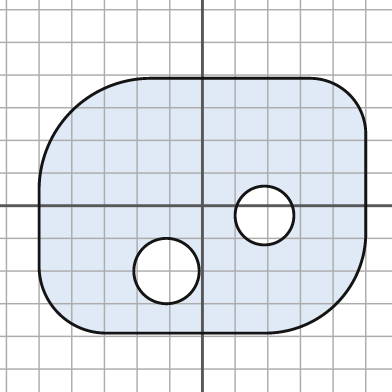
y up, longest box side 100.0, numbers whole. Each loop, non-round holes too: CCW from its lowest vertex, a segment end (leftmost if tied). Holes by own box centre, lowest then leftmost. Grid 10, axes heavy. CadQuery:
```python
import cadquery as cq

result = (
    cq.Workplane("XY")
    .moveTo(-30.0, -39.0)
    .lineTo(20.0, -39.0)
    .threePointArc((41.0, -30.0), (50.0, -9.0))
    .lineTo(50.0, 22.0)
    .threePointArc((45.0, 34.0), (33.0, 39.0))
    .lineTo(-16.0, 39.0)
    .threePointArc((-40.0, 29.0), (-50.0, 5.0))
    .lineTo(-50.0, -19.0)
    .threePointArc((-44.0, -33.0), (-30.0, -39.0))
    .close()
    .moveTo(-11.0, -20.0)
    .circle(10.0)
    .moveTo(19.0, -3.0)
    .circle(9.0)
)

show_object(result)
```